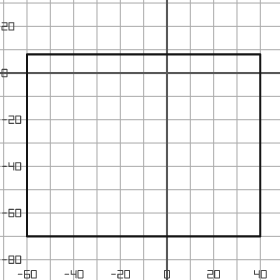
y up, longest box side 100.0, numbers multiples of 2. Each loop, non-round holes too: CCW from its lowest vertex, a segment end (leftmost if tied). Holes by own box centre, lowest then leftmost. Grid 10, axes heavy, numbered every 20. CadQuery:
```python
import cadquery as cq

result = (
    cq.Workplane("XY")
    .moveTo(-60.0, -70.0)
    .lineTo(40.0, -70.0)
    .lineTo(40.0, 8.0)
    .lineTo(-60.0, 8.0)
    .close()
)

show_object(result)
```